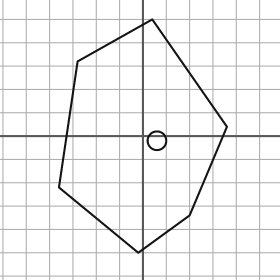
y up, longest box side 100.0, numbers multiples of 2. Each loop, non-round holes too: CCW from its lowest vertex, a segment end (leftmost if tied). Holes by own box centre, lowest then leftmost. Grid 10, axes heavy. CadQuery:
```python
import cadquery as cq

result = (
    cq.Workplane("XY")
    .moveTo(-2.0, -50.0)
    .lineTo(20.0, -34.0)
    .lineTo(36.0, 4.0)
    .lineTo(4.0, 50.0)
    .lineTo(-28.0, 32.0)
    .lineTo(-36.0, -22.0)
    .close()
    .moveTo(6.0, -2.0)
    .circle(4.0)
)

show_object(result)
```